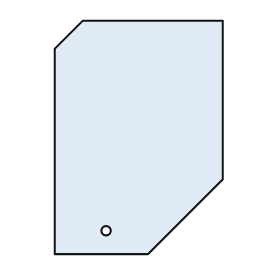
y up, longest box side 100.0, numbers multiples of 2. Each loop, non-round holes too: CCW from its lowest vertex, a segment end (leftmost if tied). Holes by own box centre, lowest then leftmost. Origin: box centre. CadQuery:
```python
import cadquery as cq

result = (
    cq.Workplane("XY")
    .moveTo(-36.0, -50.0)
    .lineTo(4.0, -50.0)
    .lineTo(36.0, -18.0)
    .lineTo(36.0, 50.0)
    .lineTo(-24.0, 50.0)
    .lineTo(-36.0, 38.0)
    .close()
    .moveTo(-14.0, -40.0)
    .circle(2.0)
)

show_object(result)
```